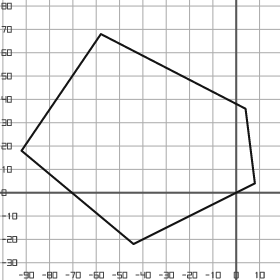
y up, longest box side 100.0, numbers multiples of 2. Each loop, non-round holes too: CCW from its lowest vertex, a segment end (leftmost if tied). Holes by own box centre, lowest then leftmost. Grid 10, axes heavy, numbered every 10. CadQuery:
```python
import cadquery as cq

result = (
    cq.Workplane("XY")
    .moveTo(-44.0, -22.0)
    .lineTo(8.0, 4.0)
    .lineTo(4.0, 36.0)
    .lineTo(-58.0, 68.0)
    .lineTo(-92.0, 18.0)
    .close()
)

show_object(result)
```